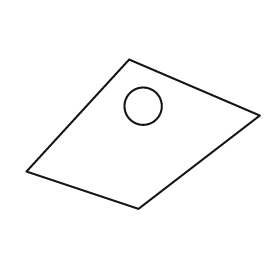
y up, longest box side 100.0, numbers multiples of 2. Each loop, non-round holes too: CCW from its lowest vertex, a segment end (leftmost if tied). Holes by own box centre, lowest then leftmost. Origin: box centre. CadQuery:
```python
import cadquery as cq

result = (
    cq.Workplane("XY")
    .moveTo(-2.0, -32.0)
    .lineTo(50.0, 8.0)
    .lineTo(-6.0, 32.0)
    .lineTo(-50.0, -16.0)
    .close()
    .moveTo(0.0, 12.0)
    .circle(8.0)
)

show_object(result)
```